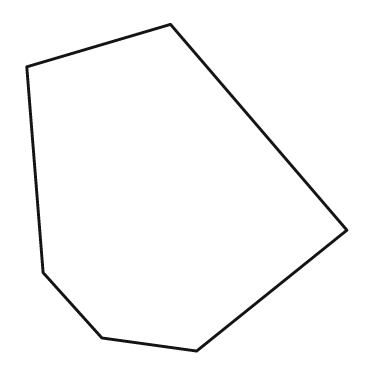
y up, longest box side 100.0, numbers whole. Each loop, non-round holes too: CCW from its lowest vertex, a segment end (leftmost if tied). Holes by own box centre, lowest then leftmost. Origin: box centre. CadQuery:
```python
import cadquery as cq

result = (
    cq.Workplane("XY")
    .moveTo(3.0, -50.0)
    .lineTo(49.0, -13.0)
    .lineTo(-5.0, 50.0)
    .lineTo(-49.0, 37.0)
    .lineTo(-44.0, -26.0)
    .lineTo(-26.0, -46.0)
    .close()
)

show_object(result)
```